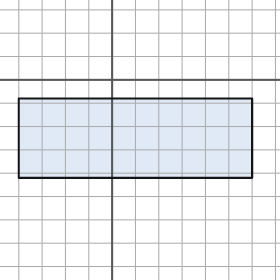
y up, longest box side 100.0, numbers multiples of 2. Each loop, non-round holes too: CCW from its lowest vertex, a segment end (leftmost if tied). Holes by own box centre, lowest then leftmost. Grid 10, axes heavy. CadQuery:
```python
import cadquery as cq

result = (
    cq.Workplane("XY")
    .moveTo(-40.0, -42.0)
    .lineTo(60.0, -42.0)
    .lineTo(60.0, -8.0)
    .lineTo(-40.0, -8.0)
    .close()
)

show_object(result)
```